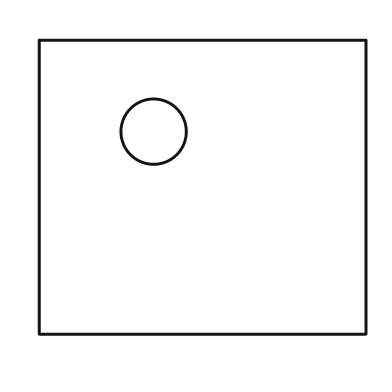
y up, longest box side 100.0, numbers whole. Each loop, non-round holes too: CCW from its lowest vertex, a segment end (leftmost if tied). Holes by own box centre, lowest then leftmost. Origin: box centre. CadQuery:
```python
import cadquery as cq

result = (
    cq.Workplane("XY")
    .moveTo(-50.0, -45.0)
    .lineTo(50.0, -45.0)
    .lineTo(50.0, 45.0)
    .lineTo(-50.0, 45.0)
    .close()
    .moveTo(-15.0, 17.0)
    .circle(10.0)
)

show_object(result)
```